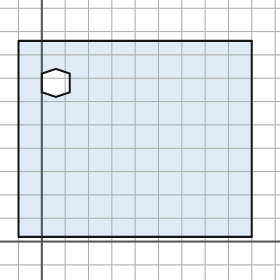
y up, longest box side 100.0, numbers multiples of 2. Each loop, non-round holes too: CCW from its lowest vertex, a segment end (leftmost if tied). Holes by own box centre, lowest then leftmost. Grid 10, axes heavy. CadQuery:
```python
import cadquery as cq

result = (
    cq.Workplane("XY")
    .moveTo(-10.0, 2.0)
    .lineTo(90.0, 2.0)
    .lineTo(90.0, 86.0)
    .lineTo(-10.0, 86.0)
    .close()
    .moveTo(6.0, 62.0)
    .lineTo(12.0, 64.0)
    .lineTo(12.0, 72.0)
    .lineTo(6.0, 74.0)
    .lineTo(0.0, 72.0)
    .lineTo(0.0, 64.0)
    .close()
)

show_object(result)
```